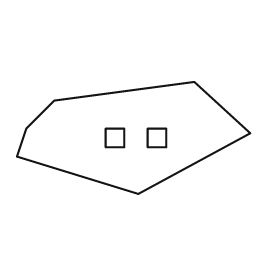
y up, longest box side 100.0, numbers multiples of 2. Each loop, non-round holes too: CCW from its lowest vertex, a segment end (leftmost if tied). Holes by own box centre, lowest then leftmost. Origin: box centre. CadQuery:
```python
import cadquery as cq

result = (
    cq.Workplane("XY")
    .moveTo(2.0, -24.0)
    .lineTo(50.0, 2.0)
    .lineTo(26.0, 24.0)
    .lineTo(-34.0, 16.0)
    .lineTo(-46.0, 4.0)
    .lineTo(-50.0, -8.0)
    .close()
    .moveTo(-12.0, -4.0)
    .lineTo(-4.0, -4.0)
    .lineTo(-4.0, 4.0)
    .lineTo(-12.0, 4.0)
    .close()
    .moveTo(6.0, -4.0)
    .lineTo(14.0, -4.0)
    .lineTo(14.0, 4.0)
    .lineTo(6.0, 4.0)
    .close()
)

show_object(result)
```